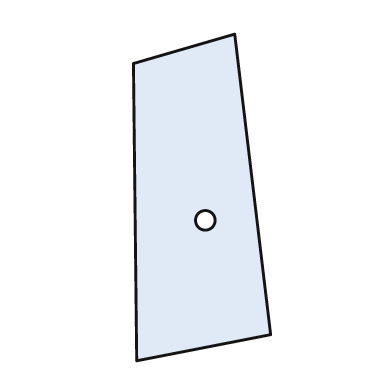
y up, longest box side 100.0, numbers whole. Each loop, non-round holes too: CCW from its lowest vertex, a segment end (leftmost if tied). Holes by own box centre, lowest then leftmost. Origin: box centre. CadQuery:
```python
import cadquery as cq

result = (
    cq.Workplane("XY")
    .moveTo(-20.0, -50.0)
    .lineTo(21.0, -42.0)
    .lineTo(10.0, 50.0)
    .lineTo(-21.0, 41.0)
    .close()
    .moveTo(1.0, -7.0)
    .circle(3.0)
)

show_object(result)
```